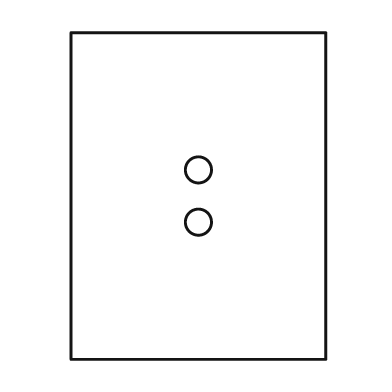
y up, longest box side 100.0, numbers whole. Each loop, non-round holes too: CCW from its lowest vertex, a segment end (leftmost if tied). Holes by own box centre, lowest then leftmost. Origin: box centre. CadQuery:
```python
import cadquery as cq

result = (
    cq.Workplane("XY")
    .moveTo(-39.0, -50.0)
    .lineTo(39.0, -50.0)
    .lineTo(39.0, 50.0)
    .lineTo(-39.0, 50.0)
    .close()
    .moveTo(0.0, -8.0)
    .circle(4.0)
    .moveTo(0.0, 8.0)
    .circle(4.0)
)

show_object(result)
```